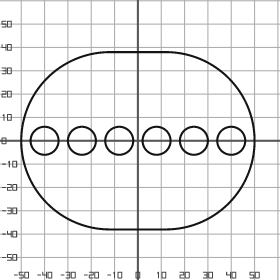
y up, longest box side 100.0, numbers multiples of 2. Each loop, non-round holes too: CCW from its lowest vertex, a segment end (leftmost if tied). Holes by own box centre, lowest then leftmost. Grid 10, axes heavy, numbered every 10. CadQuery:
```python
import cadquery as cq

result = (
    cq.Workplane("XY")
    .moveTo(-12.0, -38.0)
    .lineTo(12.0, -38.0)
    .threePointArc((50.0, 0.0), (12.0, 38.0))
    .lineTo(-12.0, 38.0)
    .threePointArc((-50.0, 0.0), (-12.0, -38.0))
    .close()
    .moveTo(-40.0, 0.0)
    .circle(6.0)
    .moveTo(-24.0, 0.0)
    .circle(6.0)
    .moveTo(-8.0, 0.0)
    .circle(6.0)
    .moveTo(8.0, 0.0)
    .circle(6.0)
    .moveTo(24.0, 0.0)
    .circle(6.0)
    .moveTo(40.0, 0.0)
    .circle(6.0)
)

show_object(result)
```